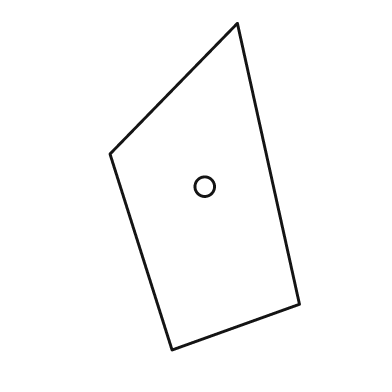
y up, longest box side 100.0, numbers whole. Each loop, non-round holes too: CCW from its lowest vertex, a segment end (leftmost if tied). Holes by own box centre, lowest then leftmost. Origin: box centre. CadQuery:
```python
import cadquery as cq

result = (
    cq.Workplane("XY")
    .moveTo(-10.0, -50.0)
    .lineTo(29.0, -36.0)
    .lineTo(10.0, 50.0)
    .lineTo(-29.0, 10.0)
    .close()
    .moveTo(0.0, 0.0)
    .circle(3.0)
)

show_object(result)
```